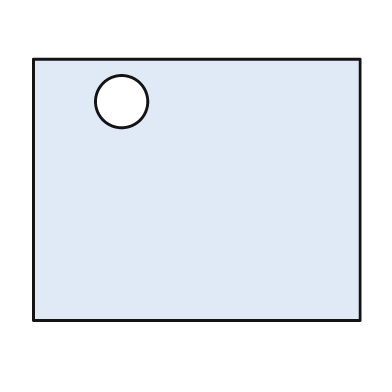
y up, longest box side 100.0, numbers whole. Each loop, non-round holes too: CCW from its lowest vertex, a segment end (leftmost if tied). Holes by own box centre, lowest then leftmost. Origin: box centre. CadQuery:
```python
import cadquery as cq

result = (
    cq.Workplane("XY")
    .moveTo(-50.0, -40.0)
    .lineTo(50.0, -40.0)
    .lineTo(50.0, 40.0)
    .lineTo(-50.0, 40.0)
    .close()
    .moveTo(-23.0, 27.0)
    .circle(8.0)
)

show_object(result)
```